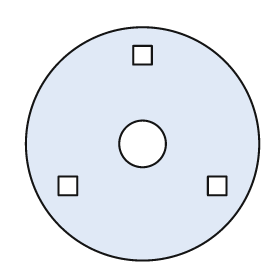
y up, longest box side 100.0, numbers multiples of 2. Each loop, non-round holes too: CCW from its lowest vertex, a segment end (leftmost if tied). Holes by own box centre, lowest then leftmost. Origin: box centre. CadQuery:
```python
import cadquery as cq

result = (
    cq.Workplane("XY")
    .moveTo(0.0, 0.0)
    .circle(50.0)
    .moveTo(-36.0, -22.0)
    .lineTo(-28.0, -22.0)
    .lineTo(-28.0, -14.0)
    .lineTo(-36.0, -14.0)
    .close()
    .moveTo(28.0, -22.0)
    .lineTo(36.0, -22.0)
    .lineTo(36.0, -14.0)
    .lineTo(28.0, -14.0)
    .close()
    .moveTo(0.0, 0.0)
    .circle(10.0)
    .moveTo(-4.0, 34.0)
    .lineTo(4.0, 34.0)
    .lineTo(4.0, 42.0)
    .lineTo(-4.0, 42.0)
    .close()
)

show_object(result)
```